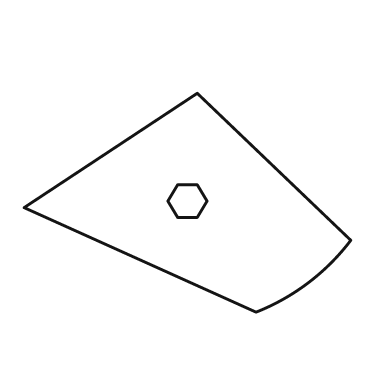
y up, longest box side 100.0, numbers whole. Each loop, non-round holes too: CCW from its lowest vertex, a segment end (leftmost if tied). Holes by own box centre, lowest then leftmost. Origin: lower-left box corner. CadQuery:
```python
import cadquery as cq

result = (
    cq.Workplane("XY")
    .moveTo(71.0, 0.0)
    .threePointArc((87.0, 9.0), (100.0, 22.0))
    .lineTo(53.0, 67.0)
    .lineTo(0.0, 32.0)
    .close()
    .moveTo(47.0, 29.0)
    .lineTo(53.0, 29.0)
    .lineTo(56.0, 34.0)
    .lineTo(53.0, 39.0)
    .lineTo(47.0, 39.0)
    .lineTo(44.0, 34.0)
    .close()
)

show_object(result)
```